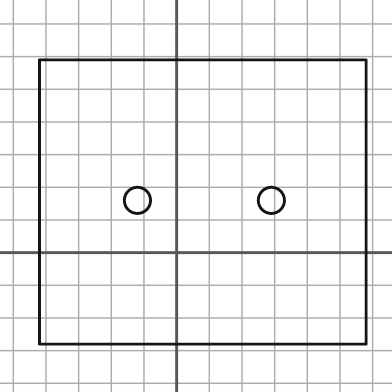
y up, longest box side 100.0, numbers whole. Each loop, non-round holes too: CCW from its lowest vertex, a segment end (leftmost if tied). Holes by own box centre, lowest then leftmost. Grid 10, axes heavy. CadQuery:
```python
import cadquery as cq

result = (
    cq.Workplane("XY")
    .moveTo(-42.0, -28.0)
    .lineTo(58.0, -28.0)
    .lineTo(58.0, 59.0)
    .lineTo(-42.0, 59.0)
    .close()
    .moveTo(-12.0, 16.0)
    .circle(4.0)
    .moveTo(29.0, 16.0)
    .circle(4.0)
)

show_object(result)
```